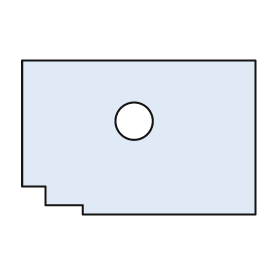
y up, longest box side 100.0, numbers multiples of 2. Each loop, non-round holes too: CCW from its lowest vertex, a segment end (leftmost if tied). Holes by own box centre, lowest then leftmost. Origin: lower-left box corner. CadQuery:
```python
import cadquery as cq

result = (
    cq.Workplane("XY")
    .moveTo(26.0, 0.0)
    .lineTo(100.0, 0.0)
    .lineTo(100.0, 66.0)
    .lineTo(0.0, 66.0)
    .lineTo(0.0, 12.0)
    .lineTo(10.0, 12.0)
    .lineTo(10.0, 4.0)
    .lineTo(26.0, 4.0)
    .close()
    .moveTo(48.0, 40.0)
    .circle(8.0)
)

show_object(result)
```